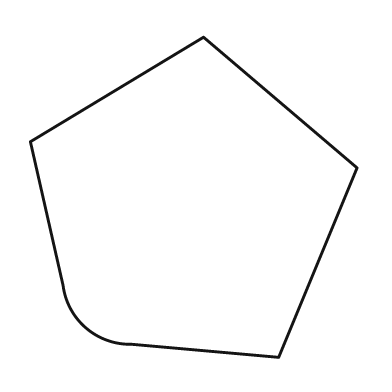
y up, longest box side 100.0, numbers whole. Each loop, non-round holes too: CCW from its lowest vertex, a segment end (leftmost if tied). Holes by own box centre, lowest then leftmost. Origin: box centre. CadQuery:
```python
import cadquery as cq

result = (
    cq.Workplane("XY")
    .moveTo(26.0, -49.0)
    .lineTo(50.0, 9.0)
    .lineTo(3.0, 49.0)
    .lineTo(-50.0, 17.0)
    .lineTo(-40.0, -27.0)
    .threePointArc((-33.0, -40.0), (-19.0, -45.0))
    .close()
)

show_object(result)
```